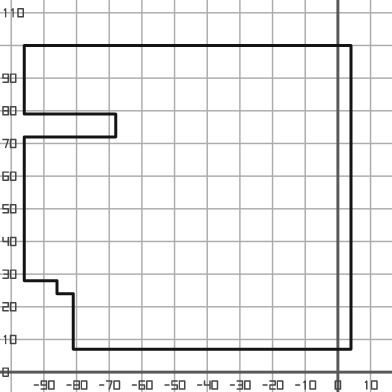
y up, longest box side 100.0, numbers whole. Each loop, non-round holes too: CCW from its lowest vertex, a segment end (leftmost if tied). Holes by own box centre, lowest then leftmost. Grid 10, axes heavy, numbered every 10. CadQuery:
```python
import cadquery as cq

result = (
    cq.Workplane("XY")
    .moveTo(-81.0, 7.0)
    .lineTo(4.0, 7.0)
    .lineTo(4.0, 100.0)
    .lineTo(-96.0, 100.0)
    .lineTo(-96.0, 79.0)
    .lineTo(-68.0, 79.0)
    .lineTo(-68.0, 72.0)
    .lineTo(-96.0, 72.0)
    .lineTo(-96.0, 28.0)
    .lineTo(-86.0, 28.0)
    .lineTo(-86.0, 24.0)
    .lineTo(-81.0, 24.0)
    .close()
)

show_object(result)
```